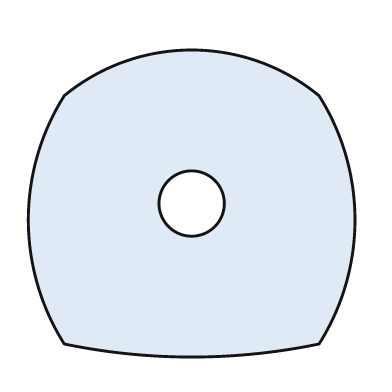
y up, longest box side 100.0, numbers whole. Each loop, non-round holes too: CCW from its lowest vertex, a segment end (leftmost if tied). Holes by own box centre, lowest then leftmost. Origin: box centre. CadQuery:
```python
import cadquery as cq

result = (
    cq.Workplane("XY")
    .moveTo(-39.0, -43.0)
    .threePointArc((0.0, -47.0), (39.0, -43.0))
    .threePointArc((50.0, -5.0), (39.0, 33.0))
    .threePointArc((0.0, 47.0), (-39.0, 33.0))
    .threePointArc((-50.0, -5.0), (-39.0, -43.0))
    .close()
    .moveTo(0.0, 0.0)
    .circle(10.0)
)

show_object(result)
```